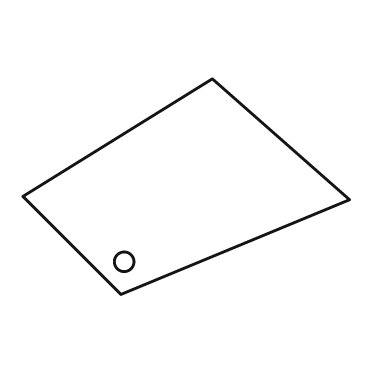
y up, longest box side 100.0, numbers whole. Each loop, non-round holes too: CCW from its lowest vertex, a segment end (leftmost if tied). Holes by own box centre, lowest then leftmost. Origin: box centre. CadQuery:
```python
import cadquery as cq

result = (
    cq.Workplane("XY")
    .moveTo(-20.0, -33.0)
    .lineTo(50.0, -4.0)
    .lineTo(8.0, 33.0)
    .lineTo(-50.0, -3.0)
    .close()
    .moveTo(-19.0, -23.0)
    .circle(3.0)
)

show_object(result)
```